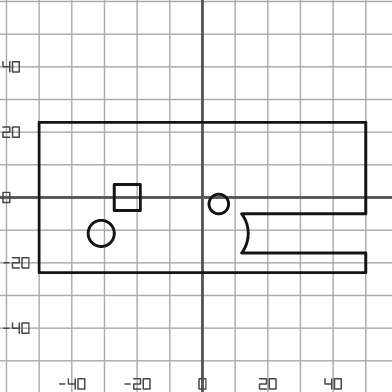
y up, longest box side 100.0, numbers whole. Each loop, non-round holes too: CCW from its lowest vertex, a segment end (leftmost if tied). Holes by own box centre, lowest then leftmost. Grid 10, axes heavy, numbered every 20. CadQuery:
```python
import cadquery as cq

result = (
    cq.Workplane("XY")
    .moveTo(-50.0, -23.0)
    .lineTo(50.0, -23.0)
    .lineTo(50.0, -17.0)
    .lineTo(12.0, -17.0)
    .threePointArc((14.0, -11.0), (12.0, -5.0))
    .lineTo(50.0, -5.0)
    .lineTo(50.0, 23.0)
    .lineTo(-50.0, 23.0)
    .close()
    .moveTo(-31.0, -11.0)
    .circle(4.0)
    .moveTo(5.0, -2.0)
    .circle(3.0)
    .moveTo(-27.0, -4.0)
    .lineTo(-19.0, -4.0)
    .lineTo(-19.0, 4.0)
    .lineTo(-27.0, 4.0)
    .close()
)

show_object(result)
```